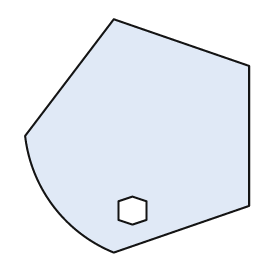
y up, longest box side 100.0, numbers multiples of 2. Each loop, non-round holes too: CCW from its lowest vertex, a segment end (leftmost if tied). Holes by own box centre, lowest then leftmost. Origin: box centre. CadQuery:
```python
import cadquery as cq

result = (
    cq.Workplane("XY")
    .moveTo(-10.0, -50.0)
    .lineTo(48.0, -30.0)
    .lineTo(48.0, 30.0)
    .lineTo(-10.0, 50.0)
    .lineTo(-48.0, 0.0)
    .threePointArc((-36.0, -30.0), (-10.0, -50.0))
    .close()
    .moveTo(-2.0, -38.0)
    .lineTo(4.0, -36.0)
    .lineTo(4.0, -28.0)
    .lineTo(-2.0, -26.0)
    .lineTo(-8.0, -28.0)
    .lineTo(-8.0, -36.0)
    .close()
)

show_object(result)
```